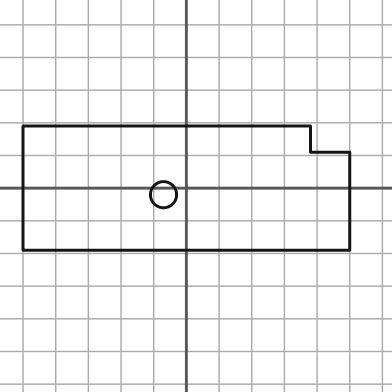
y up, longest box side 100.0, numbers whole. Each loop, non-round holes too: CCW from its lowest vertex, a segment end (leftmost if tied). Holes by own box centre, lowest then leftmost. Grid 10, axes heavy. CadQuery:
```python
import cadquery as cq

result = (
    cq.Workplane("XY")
    .moveTo(-50.0, -19.0)
    .lineTo(50.0, -19.0)
    .lineTo(50.0, 11.0)
    .lineTo(38.0, 11.0)
    .lineTo(38.0, 19.0)
    .lineTo(-50.0, 19.0)
    .close()
    .moveTo(-7.0, -2.0)
    .circle(4.0)
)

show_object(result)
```